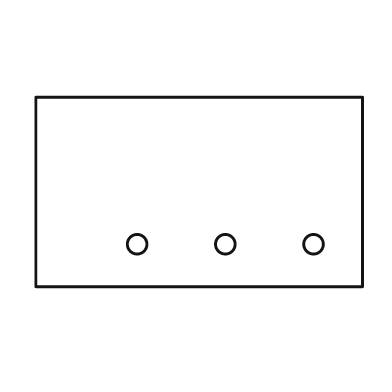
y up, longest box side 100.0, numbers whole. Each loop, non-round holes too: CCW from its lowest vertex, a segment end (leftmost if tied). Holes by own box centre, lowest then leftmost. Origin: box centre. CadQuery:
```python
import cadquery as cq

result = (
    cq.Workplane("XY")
    .moveTo(-50.0, -29.0)
    .lineTo(50.0, -29.0)
    .lineTo(50.0, 29.0)
    .lineTo(-50.0, 29.0)
    .close()
    .moveTo(-19.0, -16.0)
    .circle(3.0)
    .moveTo(8.0, -16.0)
    .circle(3.0)
    .moveTo(35.0, -16.0)
    .circle(3.0)
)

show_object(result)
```